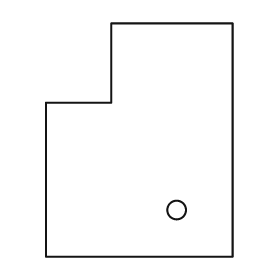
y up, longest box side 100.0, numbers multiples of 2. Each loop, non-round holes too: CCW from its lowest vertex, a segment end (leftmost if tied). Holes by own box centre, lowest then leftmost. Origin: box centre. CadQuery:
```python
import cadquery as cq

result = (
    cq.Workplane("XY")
    .moveTo(-40.0, -50.0)
    .lineTo(40.0, -50.0)
    .lineTo(40.0, 50.0)
    .lineTo(-12.0, 50.0)
    .lineTo(-12.0, 16.0)
    .lineTo(-40.0, 16.0)
    .close()
    .moveTo(16.0, -30.0)
    .circle(4.0)
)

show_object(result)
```